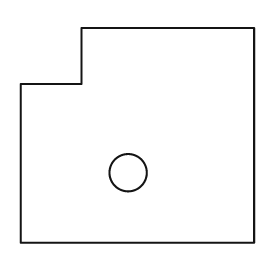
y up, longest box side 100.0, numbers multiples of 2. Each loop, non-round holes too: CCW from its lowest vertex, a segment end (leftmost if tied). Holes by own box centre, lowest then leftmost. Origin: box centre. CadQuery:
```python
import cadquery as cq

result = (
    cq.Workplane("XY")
    .moveTo(-50.0, -46.0)
    .lineTo(50.0, -46.0)
    .lineTo(50.0, 46.0)
    .lineTo(-24.0, 46.0)
    .lineTo(-24.0, 22.0)
    .lineTo(-50.0, 22.0)
    .close()
    .moveTo(-4.0, -16.0)
    .circle(8.0)
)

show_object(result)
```